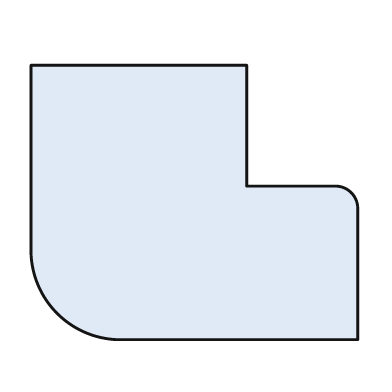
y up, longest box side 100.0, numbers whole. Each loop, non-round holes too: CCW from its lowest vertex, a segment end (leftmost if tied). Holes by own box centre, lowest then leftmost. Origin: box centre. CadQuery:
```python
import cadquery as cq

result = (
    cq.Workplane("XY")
    .moveTo(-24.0, -42.0)
    .lineTo(50.0, -42.0)
    .lineTo(50.0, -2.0)
    .threePointArc((48.0, 3.0), (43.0, 5.0))
    .lineTo(16.0, 5.0)
    .lineTo(16.0, 42.0)
    .lineTo(-50.0, 42.0)
    .lineTo(-50.0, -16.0)
    .threePointArc((-42.0, -34.0), (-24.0, -42.0))
    .close()
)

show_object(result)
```